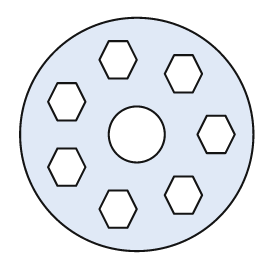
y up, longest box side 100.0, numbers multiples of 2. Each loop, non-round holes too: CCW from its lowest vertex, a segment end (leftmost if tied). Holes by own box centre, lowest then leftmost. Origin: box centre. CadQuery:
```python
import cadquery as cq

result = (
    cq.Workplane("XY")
    .moveTo(0.0, 0.0)
    .circle(50.0)
    .moveTo(-12.0, -40.0)
    .lineTo(-4.0, -40.0)
    .lineTo(0.0, -32.0)
    .lineTo(-4.0, -24.0)
    .lineTo(-12.0, -24.0)
    .lineTo(-16.0, -32.0)
    .close()
    .moveTo(16.0, -34.0)
    .lineTo(24.0, -34.0)
    .lineTo(28.0, -26.0)
    .lineTo(24.0, -18.0)
    .lineTo(16.0, -18.0)
    .lineTo(12.0, -26.0)
    .close()
    .moveTo(-34.0, -22.0)
    .lineTo(-26.0, -22.0)
    .lineTo(-22.0, -14.0)
    .lineTo(-26.0, -6.0)
    .lineTo(-34.0, -6.0)
    .lineTo(-38.0, -14.0)
    .close()
    .moveTo(0.0, 0.0)
    .circle(12.0)
    .moveTo(30.0, -8.0)
    .lineTo(38.0, -8.0)
    .lineTo(42.0, 0.0)
    .lineTo(38.0, 8.0)
    .lineTo(30.0, 8.0)
    .lineTo(26.0, 0.0)
    .close()
    .moveTo(-34.0, 6.0)
    .lineTo(-26.0, 6.0)
    .lineTo(-22.0, 14.0)
    .lineTo(-26.0, 22.0)
    .lineTo(-34.0, 22.0)
    .lineTo(-38.0, 14.0)
    .close()
    .moveTo(16.0, 18.0)
    .lineTo(24.0, 18.0)
    .lineTo(28.0, 26.0)
    .lineTo(24.0, 34.0)
    .lineTo(16.0, 34.0)
    .lineTo(12.0, 26.0)
    .close()
    .moveTo(-12.0, 24.0)
    .lineTo(-4.0, 24.0)
    .lineTo(0.0, 32.0)
    .lineTo(-4.0, 40.0)
    .lineTo(-12.0, 40.0)
    .lineTo(-16.0, 32.0)
    .close()
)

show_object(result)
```